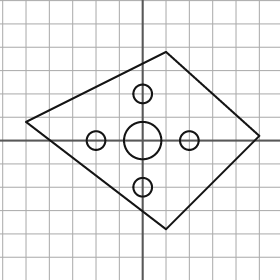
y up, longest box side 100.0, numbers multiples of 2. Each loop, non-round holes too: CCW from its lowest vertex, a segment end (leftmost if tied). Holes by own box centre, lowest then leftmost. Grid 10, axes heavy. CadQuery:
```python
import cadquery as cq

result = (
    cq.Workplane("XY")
    .moveTo(10.0, -38.0)
    .lineTo(50.0, 2.0)
    .lineTo(10.0, 38.0)
    .lineTo(-50.0, 8.0)
    .close()
    .moveTo(0.0, -20.0)
    .circle(4.0)
    .moveTo(-20.0, 0.0)
    .circle(4.0)
    .moveTo(0.0, 0.0)
    .circle(8.0)
    .moveTo(20.0, 0.0)
    .circle(4.0)
    .moveTo(0.0, 20.0)
    .circle(4.0)
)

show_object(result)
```